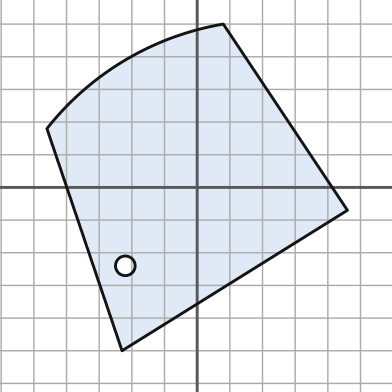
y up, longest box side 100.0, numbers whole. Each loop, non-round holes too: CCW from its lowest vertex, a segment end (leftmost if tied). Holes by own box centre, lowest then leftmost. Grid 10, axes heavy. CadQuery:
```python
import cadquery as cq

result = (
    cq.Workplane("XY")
    .moveTo(-23.0, -50.0)
    .lineTo(46.0, -7.0)
    .lineTo(8.0, 50.0)
    .threePointArc((-22.0, 39.0), (-46.0, 18.0))
    .close()
    .moveTo(-22.0, -24.0)
    .circle(3.0)
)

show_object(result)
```